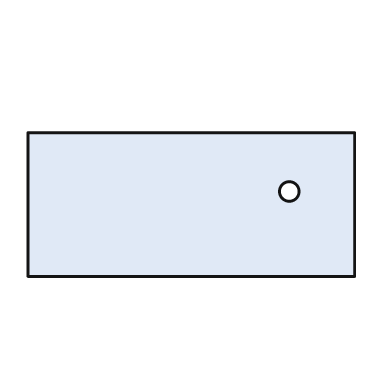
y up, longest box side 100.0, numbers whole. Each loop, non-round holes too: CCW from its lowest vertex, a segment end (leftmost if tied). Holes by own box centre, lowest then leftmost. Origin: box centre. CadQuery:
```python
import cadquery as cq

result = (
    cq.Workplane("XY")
    .moveTo(-50.0, -22.0)
    .lineTo(50.0, -22.0)
    .lineTo(50.0, 22.0)
    .lineTo(-50.0, 22.0)
    .close()
    .moveTo(30.0, 4.0)
    .circle(3.0)
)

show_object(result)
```